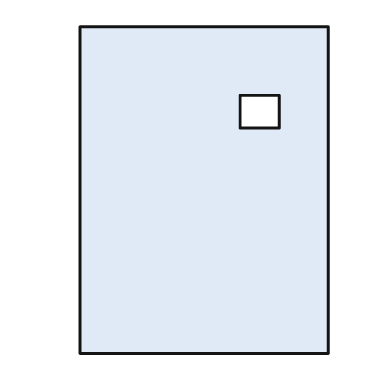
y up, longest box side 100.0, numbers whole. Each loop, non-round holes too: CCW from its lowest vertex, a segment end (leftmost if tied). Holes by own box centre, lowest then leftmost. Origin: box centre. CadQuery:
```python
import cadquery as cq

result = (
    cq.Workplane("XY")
    .moveTo(-38.0, -50.0)
    .lineTo(38.0, -50.0)
    .lineTo(38.0, 50.0)
    .lineTo(-38.0, 50.0)
    .close()
    .moveTo(11.0, 19.0)
    .lineTo(23.0, 19.0)
    .lineTo(23.0, 29.0)
    .lineTo(11.0, 29.0)
    .close()
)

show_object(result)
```